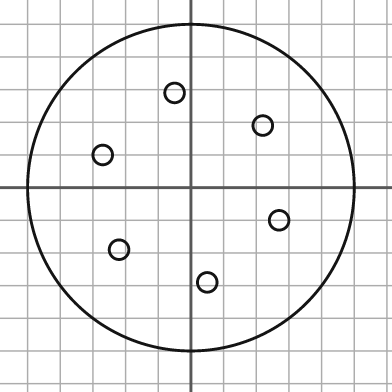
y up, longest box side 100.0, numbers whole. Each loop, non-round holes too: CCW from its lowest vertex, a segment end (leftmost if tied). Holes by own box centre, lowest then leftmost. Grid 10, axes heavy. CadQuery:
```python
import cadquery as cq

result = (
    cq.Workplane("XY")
    .moveTo(0.0, 0.0)
    .circle(50.0)
    .moveTo(5.0, -29.0)
    .circle(3.0)
    .moveTo(-22.0, -19.0)
    .circle(3.0)
    .moveTo(27.0, -10.0)
    .circle(3.0)
    .moveTo(-27.0, 10.0)
    .circle(3.0)
    .moveTo(22.0, 19.0)
    .circle(3.0)
    .moveTo(-5.0, 29.0)
    .circle(3.0)
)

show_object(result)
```